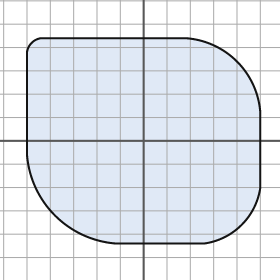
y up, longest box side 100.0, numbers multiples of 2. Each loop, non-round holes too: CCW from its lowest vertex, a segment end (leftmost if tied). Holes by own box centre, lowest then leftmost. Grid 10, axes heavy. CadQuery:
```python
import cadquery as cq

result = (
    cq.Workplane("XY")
    .moveTo(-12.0, -44.0)
    .lineTo(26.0, -44.0)
    .threePointArc((42.0, -36.0), (50.0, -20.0))
    .lineTo(50.0, 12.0)
    .threePointArc((40.0, 34.0), (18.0, 44.0))
    .lineTo(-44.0, 44.0)
    .threePointArc((-48.0, 42.0), (-50.0, 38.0))
    .lineTo(-50.0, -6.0)
    .threePointArc((-38.0, -32.0), (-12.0, -44.0))
    .close()
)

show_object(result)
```